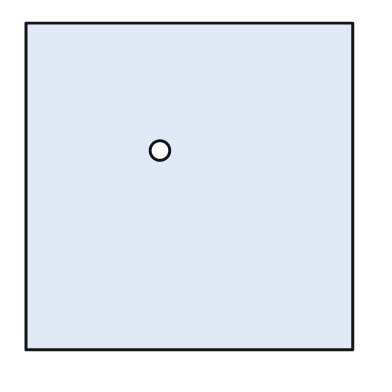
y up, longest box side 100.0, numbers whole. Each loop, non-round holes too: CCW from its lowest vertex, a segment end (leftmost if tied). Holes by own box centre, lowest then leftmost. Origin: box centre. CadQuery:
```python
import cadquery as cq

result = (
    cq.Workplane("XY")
    .moveTo(-50.0, -50.0)
    .lineTo(50.0, -50.0)
    .lineTo(50.0, 50.0)
    .lineTo(-50.0, 50.0)
    .close()
    .moveTo(-9.0, 11.0)
    .circle(3.0)
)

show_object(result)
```